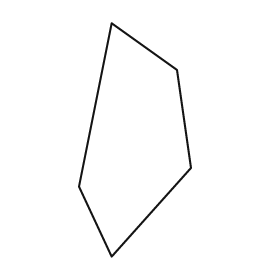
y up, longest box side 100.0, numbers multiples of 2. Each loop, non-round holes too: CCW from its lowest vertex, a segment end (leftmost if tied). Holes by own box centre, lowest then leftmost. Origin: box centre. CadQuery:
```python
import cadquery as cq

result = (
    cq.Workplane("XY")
    .moveTo(-10.0, -50.0)
    .lineTo(24.0, -12.0)
    .lineTo(18.0, 30.0)
    .lineTo(-10.0, 50.0)
    .lineTo(-24.0, -20.0)
    .close()
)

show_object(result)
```